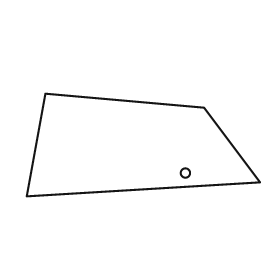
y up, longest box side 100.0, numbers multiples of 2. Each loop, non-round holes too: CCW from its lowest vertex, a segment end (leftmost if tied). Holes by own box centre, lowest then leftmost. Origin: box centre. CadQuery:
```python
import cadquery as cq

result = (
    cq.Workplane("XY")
    .moveTo(-50.0, -22.0)
    .lineTo(50.0, -16.0)
    .lineTo(26.0, 16.0)
    .lineTo(-42.0, 22.0)
    .close()
    .moveTo(18.0, -12.0)
    .circle(2.0)
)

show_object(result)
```